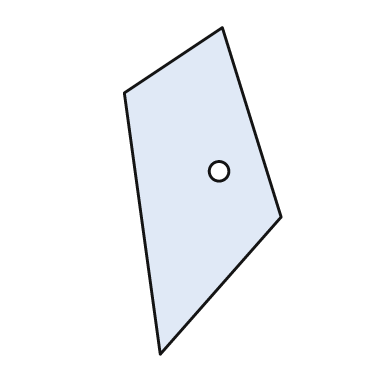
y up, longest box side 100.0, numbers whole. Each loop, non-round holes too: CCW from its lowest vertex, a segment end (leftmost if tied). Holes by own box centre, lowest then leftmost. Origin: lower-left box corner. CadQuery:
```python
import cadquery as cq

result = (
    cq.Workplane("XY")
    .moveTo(11.0, 0.0)
    .lineTo(48.0, 42.0)
    .lineTo(30.0, 100.0)
    .lineTo(0.0, 80.0)
    .close()
    .moveTo(29.0, 56.0)
    .circle(3.0)
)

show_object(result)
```